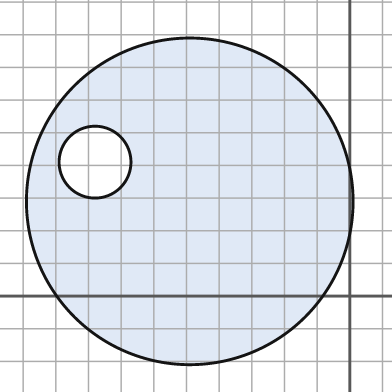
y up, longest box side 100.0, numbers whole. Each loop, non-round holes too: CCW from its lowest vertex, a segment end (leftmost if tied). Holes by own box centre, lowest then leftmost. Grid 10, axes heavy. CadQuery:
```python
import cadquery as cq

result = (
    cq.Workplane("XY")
    .moveTo(-49.0, 29.0)
    .circle(50.0)
    .moveTo(-78.0, 41.0)
    .circle(11.0)
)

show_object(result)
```